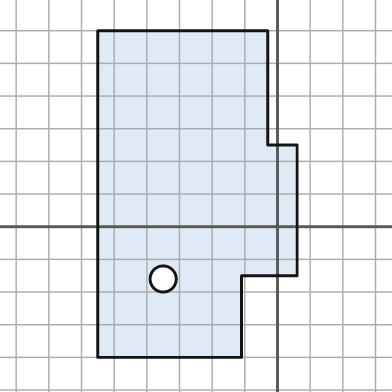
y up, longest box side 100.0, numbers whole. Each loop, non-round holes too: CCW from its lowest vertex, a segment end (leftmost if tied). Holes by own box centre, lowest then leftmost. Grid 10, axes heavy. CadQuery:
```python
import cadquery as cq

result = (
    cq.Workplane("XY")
    .moveTo(-55.0, -40.0)
    .lineTo(-11.0, -40.0)
    .lineTo(-11.0, -15.0)
    .lineTo(6.0, -15.0)
    .lineTo(6.0, 25.0)
    .lineTo(-3.0, 25.0)
    .lineTo(-3.0, 60.0)
    .lineTo(-55.0, 60.0)
    .close()
    .moveTo(-35.0, -16.0)
    .circle(4.0)
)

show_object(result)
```